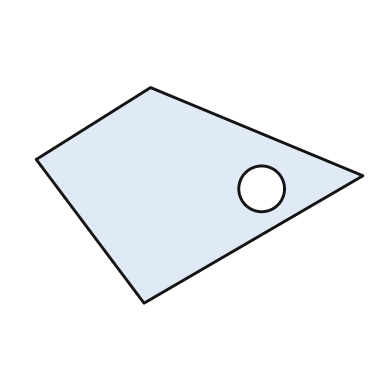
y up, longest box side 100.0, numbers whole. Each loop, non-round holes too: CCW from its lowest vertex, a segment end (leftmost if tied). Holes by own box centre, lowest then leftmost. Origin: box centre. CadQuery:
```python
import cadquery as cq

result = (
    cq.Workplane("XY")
    .moveTo(-17.0, -33.0)
    .lineTo(50.0, 6.0)
    .lineTo(-15.0, 33.0)
    .lineTo(-50.0, 11.0)
    .close()
    .moveTo(19.0, 2.0)
    .circle(7.0)
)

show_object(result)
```